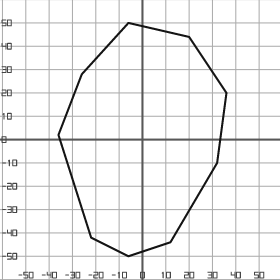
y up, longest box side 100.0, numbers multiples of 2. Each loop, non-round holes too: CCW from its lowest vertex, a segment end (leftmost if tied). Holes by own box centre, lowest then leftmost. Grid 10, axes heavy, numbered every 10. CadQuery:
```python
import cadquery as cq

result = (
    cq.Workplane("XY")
    .moveTo(-6.0, -50.0)
    .lineTo(12.0, -44.0)
    .lineTo(32.0, -10.0)
    .lineTo(36.0, 20.0)
    .lineTo(20.0, 44.0)
    .lineTo(-6.0, 50.0)
    .lineTo(-26.0, 28.0)
    .lineTo(-36.0, 2.0)
    .lineTo(-22.0, -42.0)
    .close()
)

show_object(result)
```